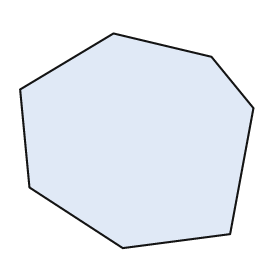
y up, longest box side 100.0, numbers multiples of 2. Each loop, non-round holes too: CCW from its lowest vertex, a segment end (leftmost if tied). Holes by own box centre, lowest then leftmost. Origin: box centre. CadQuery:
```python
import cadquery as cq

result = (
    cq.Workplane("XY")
    .moveTo(-6.0, -46.0)
    .lineTo(40.0, -40.0)
    .lineTo(50.0, 14.0)
    .lineTo(32.0, 36.0)
    .lineTo(-10.0, 46.0)
    .lineTo(-50.0, 22.0)
    .lineTo(-46.0, -20.0)
    .close()
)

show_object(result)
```